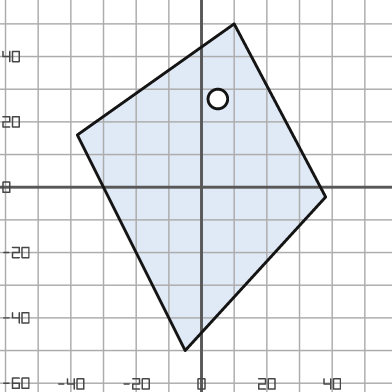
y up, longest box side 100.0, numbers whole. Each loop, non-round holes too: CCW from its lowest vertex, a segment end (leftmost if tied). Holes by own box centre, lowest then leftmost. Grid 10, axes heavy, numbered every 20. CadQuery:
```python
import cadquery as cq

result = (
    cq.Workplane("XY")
    .moveTo(-5.0, -50.0)
    .lineTo(38.0, -3.0)
    .lineTo(10.0, 50.0)
    .lineTo(-38.0, 16.0)
    .close()
    .moveTo(5.0, 27.0)
    .circle(3.0)
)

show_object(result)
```